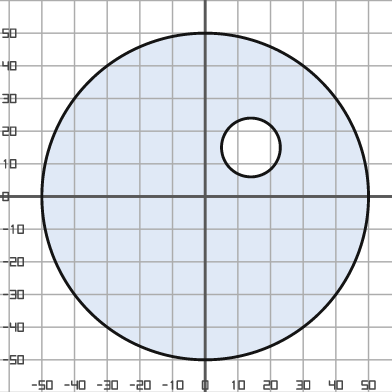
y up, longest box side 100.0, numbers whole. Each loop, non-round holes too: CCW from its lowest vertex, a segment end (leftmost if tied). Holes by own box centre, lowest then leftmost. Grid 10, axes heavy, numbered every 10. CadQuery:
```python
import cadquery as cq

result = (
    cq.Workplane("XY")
    .moveTo(0.0, 0.0)
    .circle(50.0)
    .moveTo(14.0, 15.0)
    .circle(9.0)
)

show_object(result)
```